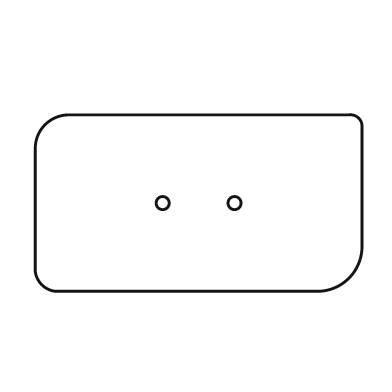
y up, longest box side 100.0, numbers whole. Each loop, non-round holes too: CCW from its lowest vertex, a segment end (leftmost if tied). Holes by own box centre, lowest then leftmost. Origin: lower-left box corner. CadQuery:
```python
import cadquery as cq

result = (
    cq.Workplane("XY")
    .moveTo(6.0, 0.0)
    .lineTo(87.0, 0.0)
    .threePointArc((96.0, 4.0), (100.0, 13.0))
    .lineTo(100.0, 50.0)
    .threePointArc((99.0, 53.0), (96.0, 54.0))
    .lineTo(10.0, 54.0)
    .threePointArc((3.0, 51.0), (0.0, 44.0))
    .lineTo(0.0, 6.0)
    .threePointArc((2.0, 2.0), (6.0, 0.0))
    .close()
    .moveTo(39.0, 27.0)
    .circle(2.0)
    .moveTo(61.0, 27.0)
    .circle(2.0)
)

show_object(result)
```